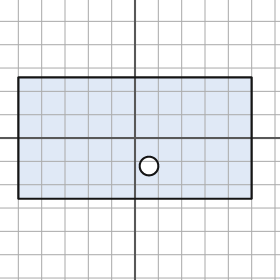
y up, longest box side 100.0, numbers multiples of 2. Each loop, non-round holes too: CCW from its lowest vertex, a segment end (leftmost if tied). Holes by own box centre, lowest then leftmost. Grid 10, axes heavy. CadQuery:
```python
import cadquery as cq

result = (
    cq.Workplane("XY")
    .moveTo(-50.0, -26.0)
    .lineTo(50.0, -26.0)
    .lineTo(50.0, 26.0)
    .lineTo(-50.0, 26.0)
    .close()
    .moveTo(6.0, -12.0)
    .circle(4.0)
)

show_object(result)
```